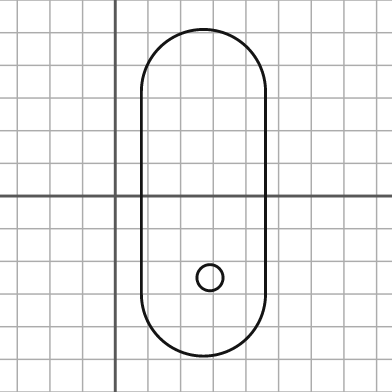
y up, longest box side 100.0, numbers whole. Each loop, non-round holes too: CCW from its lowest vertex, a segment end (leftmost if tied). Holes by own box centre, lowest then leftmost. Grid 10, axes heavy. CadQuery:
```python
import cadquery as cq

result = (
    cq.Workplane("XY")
    .moveTo(8.0, -30.0)
    .threePointArc((27.0, -49.0), (46.0, -30.0))
    .lineTo(46.0, 32.0)
    .threePointArc((27.0, 51.0), (8.0, 32.0))
    .close()
    .moveTo(29.0, -25.0)
    .circle(4.0)
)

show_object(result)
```